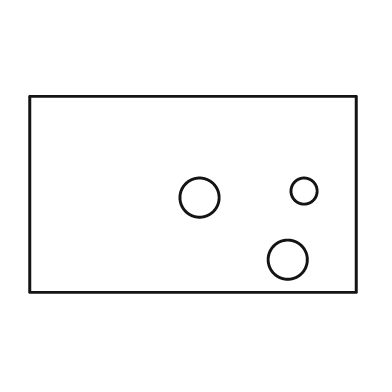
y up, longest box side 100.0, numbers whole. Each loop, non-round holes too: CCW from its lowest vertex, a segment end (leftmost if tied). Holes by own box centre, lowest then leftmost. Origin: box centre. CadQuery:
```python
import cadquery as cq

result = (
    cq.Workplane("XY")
    .moveTo(-50.0, -30.0)
    .lineTo(50.0, -30.0)
    .lineTo(50.0, 30.0)
    .lineTo(-50.0, 30.0)
    .close()
    .moveTo(29.0, -20.0)
    .circle(6.0)
    .moveTo(2.0, -1.0)
    .circle(6.0)
    .moveTo(34.0, 1.0)
    .circle(4.0)
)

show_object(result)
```